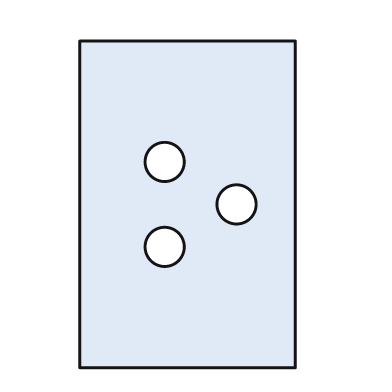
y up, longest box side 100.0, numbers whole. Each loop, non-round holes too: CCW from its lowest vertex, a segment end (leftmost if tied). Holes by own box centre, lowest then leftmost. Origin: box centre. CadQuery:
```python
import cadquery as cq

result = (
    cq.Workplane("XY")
    .moveTo(-33.0, -50.0)
    .lineTo(33.0, -50.0)
    .lineTo(33.0, 50.0)
    .lineTo(-33.0, 50.0)
    .close()
    .moveTo(-7.0, -13.0)
    .circle(6.0)
    .moveTo(15.0, 0.0)
    .circle(6.0)
    .moveTo(-7.0, 13.0)
    .circle(6.0)
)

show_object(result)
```